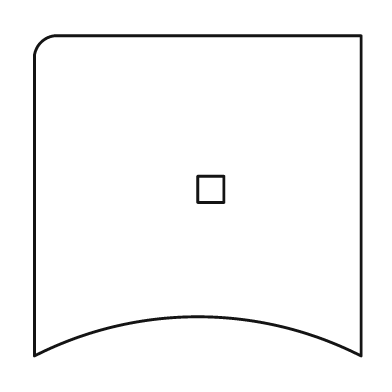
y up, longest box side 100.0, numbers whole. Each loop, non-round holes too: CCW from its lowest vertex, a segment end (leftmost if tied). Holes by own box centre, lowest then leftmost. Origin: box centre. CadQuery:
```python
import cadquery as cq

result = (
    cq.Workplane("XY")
    .moveTo(-50.0, -49.0)
    .threePointArc((0.0, -37.0), (50.0, -49.0))
    .lineTo(50.0, 49.0)
    .lineTo(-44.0, 49.0)
    .threePointArc((-48.0, 47.0), (-50.0, 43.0))
    .close()
    .moveTo(0.0, -2.0)
    .lineTo(8.0, -2.0)
    .lineTo(8.0, 6.0)
    .lineTo(0.0, 6.0)
    .close()
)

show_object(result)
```